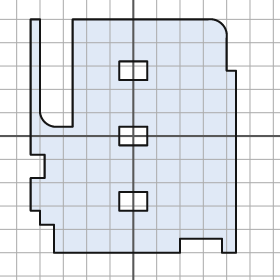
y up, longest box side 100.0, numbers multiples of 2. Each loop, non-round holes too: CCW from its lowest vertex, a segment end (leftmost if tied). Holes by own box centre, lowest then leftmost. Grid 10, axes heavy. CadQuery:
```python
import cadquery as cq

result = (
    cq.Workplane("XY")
    .moveTo(-34.0, -50.0)
    .lineTo(20.0, -50.0)
    .lineTo(20.0, -44.0)
    .lineTo(38.0, -44.0)
    .lineTo(38.0, -50.0)
    .lineTo(44.0, -50.0)
    .lineTo(44.0, 28.0)
    .lineTo(40.0, 28.0)
    .lineTo(40.0, 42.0)
    .threePointArc((38.0, 48.0), (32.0, 50.0))
    .lineTo(-26.0, 50.0)
    .lineTo(-26.0, 4.0)
    .lineTo(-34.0, 4.0)
    .threePointArc((-38.0, 6.0), (-40.0, 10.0))
    .lineTo(-40.0, 50.0)
    .lineTo(-44.0, 50.0)
    .lineTo(-44.0, -8.0)
    .lineTo(-38.0, -8.0)
    .lineTo(-38.0, -18.0)
    .lineTo(-44.0, -18.0)
    .lineTo(-44.0, -32.0)
    .lineTo(-40.0, -32.0)
    .lineTo(-40.0, -38.0)
    .lineTo(-34.0, -38.0)
    .close()
    .moveTo(-6.0, -32.0)
    .lineTo(6.0, -32.0)
    .lineTo(6.0, -24.0)
    .lineTo(-6.0, -24.0)
    .close()
    .moveTo(-6.0, -4.0)
    .lineTo(6.0, -4.0)
    .lineTo(6.0, 4.0)
    .lineTo(-6.0, 4.0)
    .close()
    .moveTo(-6.0, 24.0)
    .lineTo(6.0, 24.0)
    .lineTo(6.0, 32.0)
    .lineTo(-6.0, 32.0)
    .close()
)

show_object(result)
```